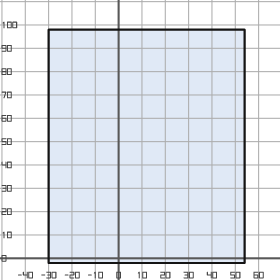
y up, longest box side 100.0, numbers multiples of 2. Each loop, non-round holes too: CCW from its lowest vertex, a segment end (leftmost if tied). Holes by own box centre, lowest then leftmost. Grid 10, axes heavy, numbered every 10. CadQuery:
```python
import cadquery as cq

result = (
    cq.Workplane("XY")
    .moveTo(-30.0, -2.0)
    .lineTo(54.0, -2.0)
    .lineTo(54.0, 98.0)
    .lineTo(-30.0, 98.0)
    .close()
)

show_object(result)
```